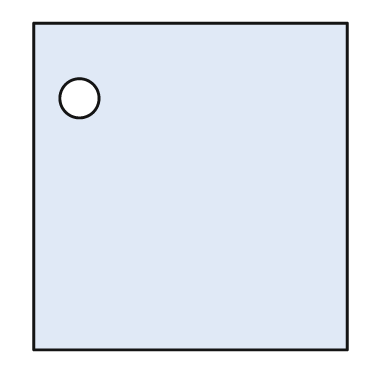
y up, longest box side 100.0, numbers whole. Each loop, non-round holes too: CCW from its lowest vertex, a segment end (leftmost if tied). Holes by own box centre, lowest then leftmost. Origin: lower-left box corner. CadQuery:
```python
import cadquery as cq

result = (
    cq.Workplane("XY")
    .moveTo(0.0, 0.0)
    .lineTo(96.0, 0.0)
    .lineTo(96.0, 100.0)
    .lineTo(0.0, 100.0)
    .close()
    .moveTo(14.0, 77.0)
    .circle(6.0)
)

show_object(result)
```